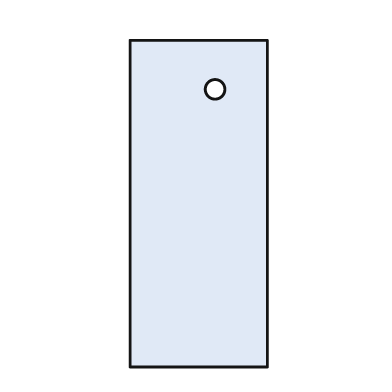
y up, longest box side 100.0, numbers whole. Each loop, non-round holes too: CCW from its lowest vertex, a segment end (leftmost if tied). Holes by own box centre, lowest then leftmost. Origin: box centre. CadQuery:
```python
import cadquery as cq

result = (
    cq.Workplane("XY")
    .moveTo(-21.0, -50.0)
    .lineTo(21.0, -50.0)
    .lineTo(21.0, 50.0)
    .lineTo(-21.0, 50.0)
    .close()
    .moveTo(5.0, 35.0)
    .circle(3.0)
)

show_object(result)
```